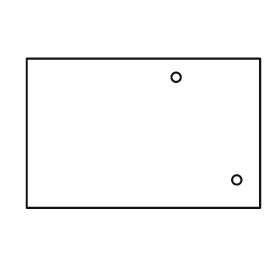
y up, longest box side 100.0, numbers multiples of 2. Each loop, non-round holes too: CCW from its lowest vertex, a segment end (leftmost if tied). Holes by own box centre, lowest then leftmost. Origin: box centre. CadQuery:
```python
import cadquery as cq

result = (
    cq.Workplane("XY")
    .moveTo(-50.0, -32.0)
    .lineTo(50.0, -32.0)
    .lineTo(50.0, 32.0)
    .lineTo(-50.0, 32.0)
    .close()
    .moveTo(40.0, -20.0)
    .circle(2.0)
    .moveTo(14.0, 24.0)
    .circle(2.0)
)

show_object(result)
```